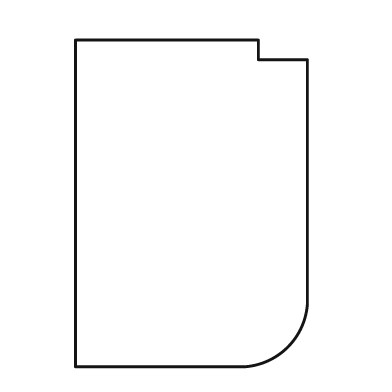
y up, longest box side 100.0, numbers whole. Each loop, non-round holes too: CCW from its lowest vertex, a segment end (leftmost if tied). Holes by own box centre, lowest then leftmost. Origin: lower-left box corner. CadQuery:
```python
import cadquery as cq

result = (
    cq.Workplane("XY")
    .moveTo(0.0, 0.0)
    .lineTo(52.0, 0.0)
    .threePointArc((65.0, 6.0), (71.0, 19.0))
    .lineTo(71.0, 94.0)
    .lineTo(56.0, 94.0)
    .lineTo(56.0, 100.0)
    .lineTo(0.0, 100.0)
    .close()
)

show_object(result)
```